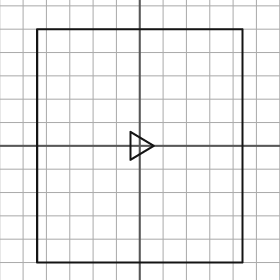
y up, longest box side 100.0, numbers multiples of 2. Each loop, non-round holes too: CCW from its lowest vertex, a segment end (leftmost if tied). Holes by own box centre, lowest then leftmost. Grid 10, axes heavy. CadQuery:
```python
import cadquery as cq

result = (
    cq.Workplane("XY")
    .moveTo(-44.0, -50.0)
    .lineTo(44.0, -50.0)
    .lineTo(44.0, 50.0)
    .lineTo(-44.0, 50.0)
    .close()
    .moveTo(-4.0, -6.0)
    .lineTo(6.0, 0.0)
    .lineTo(-4.0, 6.0)
    .close()
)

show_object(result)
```